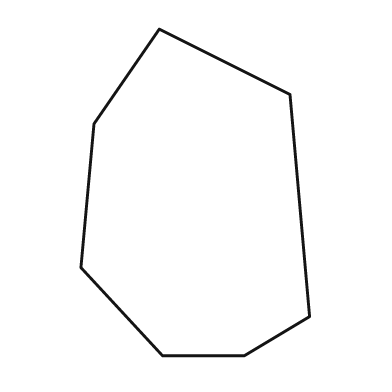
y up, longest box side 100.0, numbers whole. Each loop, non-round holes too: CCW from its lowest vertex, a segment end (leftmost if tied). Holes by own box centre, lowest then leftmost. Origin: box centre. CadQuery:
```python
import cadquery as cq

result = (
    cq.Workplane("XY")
    .moveTo(-10.0, -50.0)
    .lineTo(15.0, -50.0)
    .lineTo(35.0, -38.0)
    .lineTo(29.0, 30.0)
    .lineTo(-11.0, 50.0)
    .lineTo(-31.0, 21.0)
    .lineTo(-35.0, -23.0)
    .close()
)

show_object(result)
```